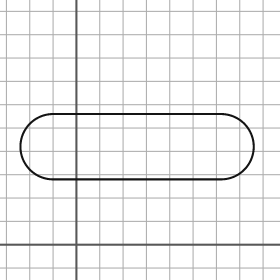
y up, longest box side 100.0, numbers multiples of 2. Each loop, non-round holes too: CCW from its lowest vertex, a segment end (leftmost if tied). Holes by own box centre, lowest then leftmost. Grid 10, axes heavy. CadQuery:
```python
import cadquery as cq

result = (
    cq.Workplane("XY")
    .moveTo(-10.0, 28.0)
    .lineTo(62.0, 28.0)
    .threePointArc((76.0, 42.0), (62.0, 56.0))
    .lineTo(-10.0, 56.0)
    .threePointArc((-24.0, 42.0), (-10.0, 28.0))
    .close()
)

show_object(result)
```